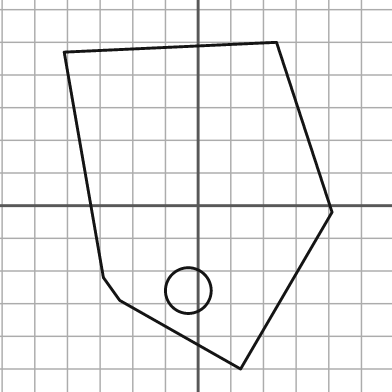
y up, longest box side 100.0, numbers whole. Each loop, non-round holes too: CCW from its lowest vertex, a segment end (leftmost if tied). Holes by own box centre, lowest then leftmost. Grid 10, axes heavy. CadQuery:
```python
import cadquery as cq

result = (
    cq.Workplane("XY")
    .moveTo(13.0, -50.0)
    .lineTo(41.0, -2.0)
    .lineTo(24.0, 50.0)
    .lineTo(-41.0, 47.0)
    .lineTo(-29.0, -22.0)
    .lineTo(-24.0, -29.0)
    .close()
    .moveTo(-3.0, -26.0)
    .circle(7.0)
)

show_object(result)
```